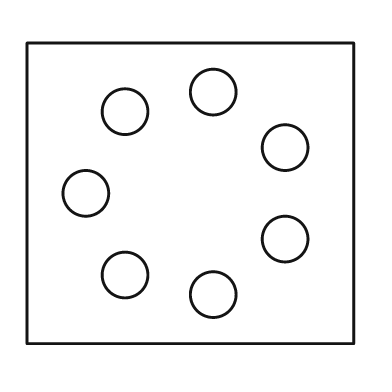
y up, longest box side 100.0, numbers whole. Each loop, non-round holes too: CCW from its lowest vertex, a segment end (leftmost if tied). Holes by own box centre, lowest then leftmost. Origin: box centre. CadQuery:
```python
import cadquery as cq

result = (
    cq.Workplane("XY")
    .moveTo(-50.0, -46.0)
    .lineTo(50.0, -46.0)
    .lineTo(50.0, 46.0)
    .lineTo(-50.0, 46.0)
    .close()
    .moveTo(7.0, -31.0)
    .circle(7.0)
    .moveTo(-20.0, -25.0)
    .circle(7.0)
    .moveTo(29.0, -14.0)
    .circle(7.0)
    .moveTo(-32.0, 0.0)
    .circle(7.0)
    .moveTo(29.0, 14.0)
    .circle(7.0)
    .moveTo(-20.0, 25.0)
    .circle(7.0)
    .moveTo(7.0, 31.0)
    .circle(7.0)
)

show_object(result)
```